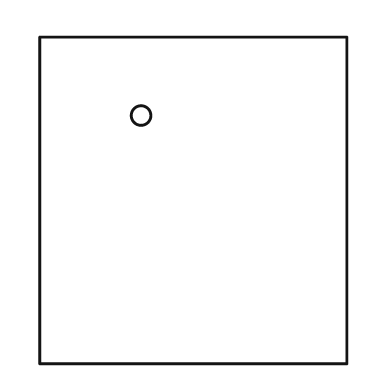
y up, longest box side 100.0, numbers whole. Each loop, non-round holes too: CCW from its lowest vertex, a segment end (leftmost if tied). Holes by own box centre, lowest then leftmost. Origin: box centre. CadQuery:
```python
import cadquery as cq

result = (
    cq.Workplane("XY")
    .moveTo(-47.0, -50.0)
    .lineTo(47.0, -50.0)
    .lineTo(47.0, 50.0)
    .lineTo(-47.0, 50.0)
    .close()
    .moveTo(-16.0, 26.0)
    .circle(3.0)
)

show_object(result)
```